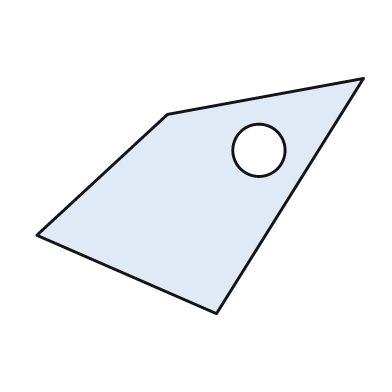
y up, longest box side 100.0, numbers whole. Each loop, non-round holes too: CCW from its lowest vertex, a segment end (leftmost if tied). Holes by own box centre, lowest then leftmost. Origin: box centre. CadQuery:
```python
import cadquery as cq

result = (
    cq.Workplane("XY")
    .moveTo(5.0, -36.0)
    .lineTo(50.0, 36.0)
    .lineTo(-10.0, 25.0)
    .lineTo(-50.0, -12.0)
    .close()
    .moveTo(18.0, 14.0)
    .circle(8.0)
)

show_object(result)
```